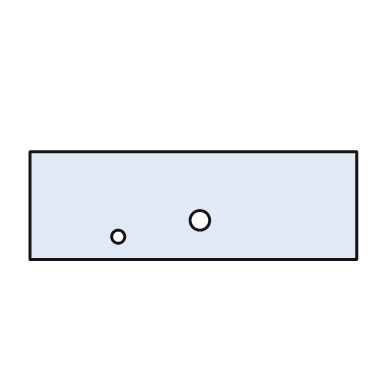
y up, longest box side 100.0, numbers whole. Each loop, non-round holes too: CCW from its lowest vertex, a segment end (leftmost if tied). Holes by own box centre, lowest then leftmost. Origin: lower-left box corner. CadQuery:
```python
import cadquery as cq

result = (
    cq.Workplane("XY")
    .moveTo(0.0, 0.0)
    .lineTo(100.0, 0.0)
    .lineTo(100.0, 33.0)
    .lineTo(0.0, 33.0)
    .close()
    .moveTo(27.0, 7.0)
    .circle(2.0)
    .moveTo(52.0, 12.0)
    .circle(3.0)
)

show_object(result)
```